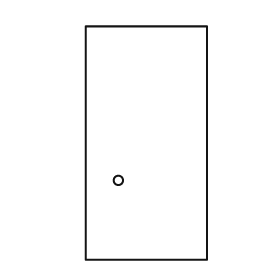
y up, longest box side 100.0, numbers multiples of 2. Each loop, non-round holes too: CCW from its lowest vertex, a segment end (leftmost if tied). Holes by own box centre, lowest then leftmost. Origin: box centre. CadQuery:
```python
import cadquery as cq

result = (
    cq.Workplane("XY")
    .moveTo(-26.0, -50.0)
    .lineTo(26.0, -50.0)
    .lineTo(26.0, 50.0)
    .lineTo(-26.0, 50.0)
    .close()
    .moveTo(-12.0, -16.0)
    .circle(2.0)
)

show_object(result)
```